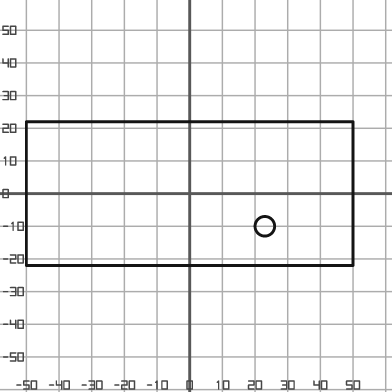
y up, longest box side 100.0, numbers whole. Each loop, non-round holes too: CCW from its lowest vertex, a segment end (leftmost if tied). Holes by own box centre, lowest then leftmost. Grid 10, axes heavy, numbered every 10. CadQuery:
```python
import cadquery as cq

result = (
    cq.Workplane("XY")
    .moveTo(-50.0, -22.0)
    .lineTo(50.0, -22.0)
    .lineTo(50.0, 22.0)
    .lineTo(-50.0, 22.0)
    .close()
    .moveTo(23.0, -10.0)
    .circle(3.0)
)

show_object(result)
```